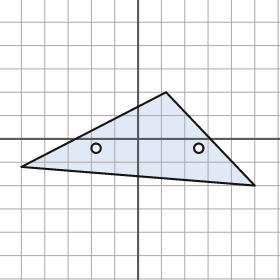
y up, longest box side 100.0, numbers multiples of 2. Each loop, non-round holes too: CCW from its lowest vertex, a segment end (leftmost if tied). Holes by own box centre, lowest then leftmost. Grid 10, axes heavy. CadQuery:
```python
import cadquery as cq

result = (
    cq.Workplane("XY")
    .moveTo(50.0, -20.0)
    .lineTo(12.0, 20.0)
    .lineTo(-50.0, -12.0)
    .close()
    .moveTo(-18.0, -4.0)
    .circle(2.0)
    .moveTo(26.0, -4.0)
    .circle(2.0)
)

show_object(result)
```